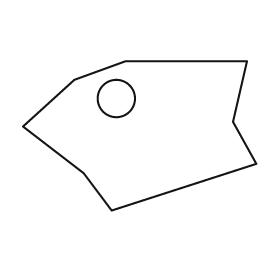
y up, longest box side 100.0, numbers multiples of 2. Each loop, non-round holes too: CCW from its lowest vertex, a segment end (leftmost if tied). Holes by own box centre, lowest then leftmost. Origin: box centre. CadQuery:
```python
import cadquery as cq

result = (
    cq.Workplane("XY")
    .moveTo(-12.0, -32.0)
    .lineTo(50.0, -12.0)
    .lineTo(40.0, 6.0)
    .lineTo(46.0, 32.0)
    .lineTo(-6.0, 32.0)
    .lineTo(-28.0, 24.0)
    .lineTo(-50.0, 4.0)
    .lineTo(-24.0, -16.0)
    .close()
    .moveTo(-10.0, 16.0)
    .circle(8.0)
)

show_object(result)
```